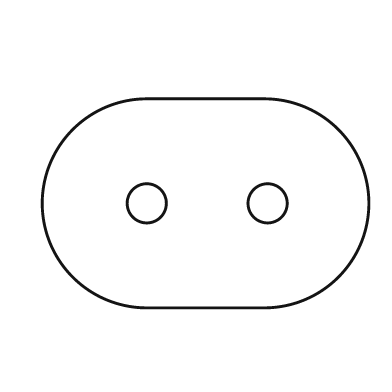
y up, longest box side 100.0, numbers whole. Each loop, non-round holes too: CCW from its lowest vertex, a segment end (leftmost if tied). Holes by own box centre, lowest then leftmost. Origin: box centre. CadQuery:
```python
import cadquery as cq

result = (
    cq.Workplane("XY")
    .moveTo(-18.0, -32.0)
    .lineTo(18.0, -32.0)
    .threePointArc((50.0, 0.0), (18.0, 32.0))
    .lineTo(-18.0, 32.0)
    .threePointArc((-50.0, 0.0), (-18.0, -32.0))
    .close()
    .moveTo(-18.0, 0.0)
    .circle(6.0)
    .moveTo(19.0, 0.0)
    .circle(6.0)
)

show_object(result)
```